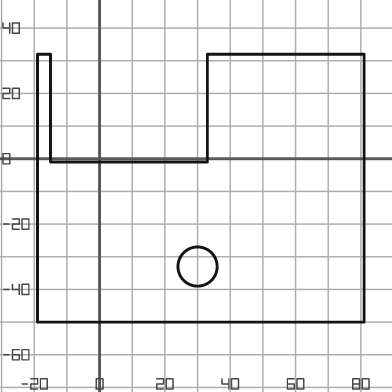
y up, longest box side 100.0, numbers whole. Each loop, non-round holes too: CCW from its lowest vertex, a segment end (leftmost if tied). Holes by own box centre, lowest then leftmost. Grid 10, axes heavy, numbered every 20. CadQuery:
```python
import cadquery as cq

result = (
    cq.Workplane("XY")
    .moveTo(-19.0, -50.0)
    .lineTo(81.0, -50.0)
    .lineTo(81.0, 32.0)
    .lineTo(33.0, 32.0)
    .lineTo(33.0, -1.0)
    .lineTo(-15.0, -1.0)
    .lineTo(-15.0, 32.0)
    .lineTo(-19.0, 32.0)
    .close()
    .moveTo(30.0, -33.0)
    .circle(6.0)
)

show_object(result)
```